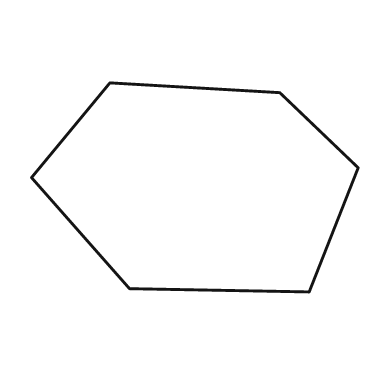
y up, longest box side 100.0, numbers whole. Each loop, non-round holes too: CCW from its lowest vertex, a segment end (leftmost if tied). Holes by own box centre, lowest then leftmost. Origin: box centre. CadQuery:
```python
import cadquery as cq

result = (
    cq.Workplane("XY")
    .moveTo(35.0, -32.0)
    .lineTo(50.0, 6.0)
    .lineTo(26.0, 29.0)
    .lineTo(-26.0, 32.0)
    .lineTo(-50.0, 3.0)
    .lineTo(-20.0, -31.0)
    .close()
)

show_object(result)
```